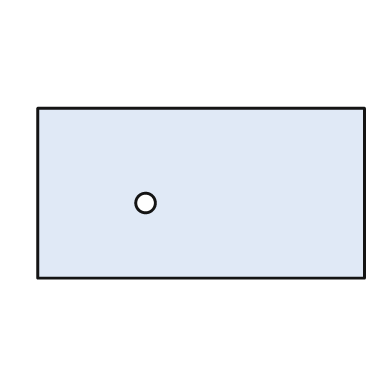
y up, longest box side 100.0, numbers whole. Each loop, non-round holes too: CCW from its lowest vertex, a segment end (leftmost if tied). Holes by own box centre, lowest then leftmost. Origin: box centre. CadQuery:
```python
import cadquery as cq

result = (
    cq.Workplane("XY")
    .moveTo(-50.0, -26.0)
    .lineTo(50.0, -26.0)
    .lineTo(50.0, 26.0)
    .lineTo(-50.0, 26.0)
    .close()
    .moveTo(-17.0, -3.0)
    .circle(3.0)
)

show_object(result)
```